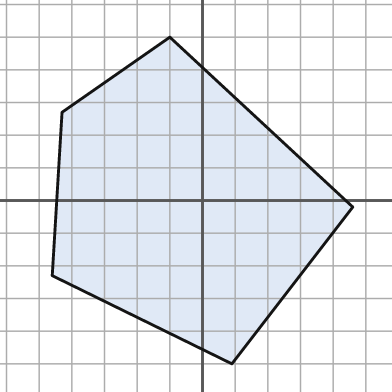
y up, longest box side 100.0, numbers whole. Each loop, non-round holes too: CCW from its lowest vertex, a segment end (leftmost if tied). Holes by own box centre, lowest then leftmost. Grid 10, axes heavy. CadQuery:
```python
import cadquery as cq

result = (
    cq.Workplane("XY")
    .moveTo(9.0, -50.0)
    .lineTo(46.0, -2.0)
    .lineTo(-10.0, 50.0)
    .lineTo(-43.0, 27.0)
    .lineTo(-46.0, -23.0)
    .close()
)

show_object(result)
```